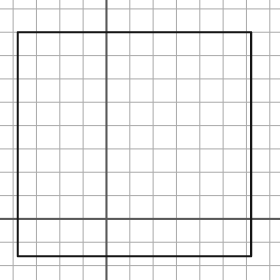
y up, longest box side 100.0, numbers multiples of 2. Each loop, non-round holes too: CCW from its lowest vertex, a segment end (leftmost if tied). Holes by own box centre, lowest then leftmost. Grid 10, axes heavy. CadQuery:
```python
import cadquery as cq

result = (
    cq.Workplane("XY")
    .moveTo(-38.0, -16.0)
    .lineTo(62.0, -16.0)
    .lineTo(62.0, 80.0)
    .lineTo(-38.0, 80.0)
    .close()
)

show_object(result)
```